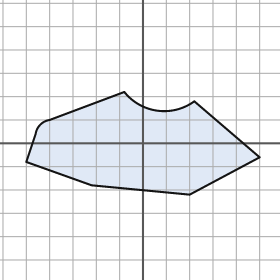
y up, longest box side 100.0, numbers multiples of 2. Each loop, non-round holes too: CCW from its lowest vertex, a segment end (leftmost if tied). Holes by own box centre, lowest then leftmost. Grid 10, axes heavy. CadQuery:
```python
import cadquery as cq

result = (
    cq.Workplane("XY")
    .moveTo(20.0, -22.0)
    .lineTo(50.0, -6.0)
    .lineTo(22.0, 18.0)
    .threePointArc((6.0, 14.0), (-8.0, 22.0))
    .lineTo(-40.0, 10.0)
    .threePointArc((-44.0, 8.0), (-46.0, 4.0))
    .lineTo(-50.0, -8.0)
    .lineTo(-22.0, -18.0)
    .close()
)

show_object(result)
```